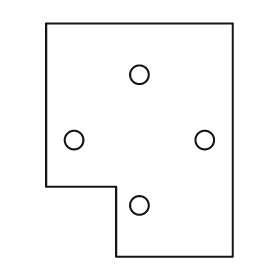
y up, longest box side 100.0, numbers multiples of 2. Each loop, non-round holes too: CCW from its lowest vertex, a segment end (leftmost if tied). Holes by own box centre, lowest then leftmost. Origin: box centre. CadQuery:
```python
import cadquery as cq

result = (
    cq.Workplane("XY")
    .moveTo(-10.0, -50.0)
    .lineTo(40.0, -50.0)
    .lineTo(40.0, 50.0)
    .lineTo(-40.0, 50.0)
    .lineTo(-40.0, -20.0)
    .lineTo(-10.0, -20.0)
    .close()
    .moveTo(0.0, -28.0)
    .circle(4.0)
    .moveTo(-28.0, 0.0)
    .circle(4.0)
    .moveTo(28.0, 0.0)
    .circle(4.0)
    .moveTo(0.0, 28.0)
    .circle(4.0)
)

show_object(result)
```